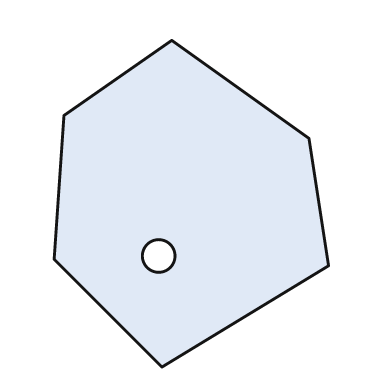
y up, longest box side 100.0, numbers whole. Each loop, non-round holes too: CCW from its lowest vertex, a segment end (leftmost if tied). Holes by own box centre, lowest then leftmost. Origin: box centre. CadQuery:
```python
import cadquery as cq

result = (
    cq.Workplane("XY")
    .moveTo(-9.0, -50.0)
    .lineTo(42.0, -19.0)
    .lineTo(36.0, 20.0)
    .lineTo(-6.0, 50.0)
    .lineTo(-39.0, 27.0)
    .lineTo(-42.0, -17.0)
    .close()
    .moveTo(-10.0, -16.0)
    .circle(5.0)
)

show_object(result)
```